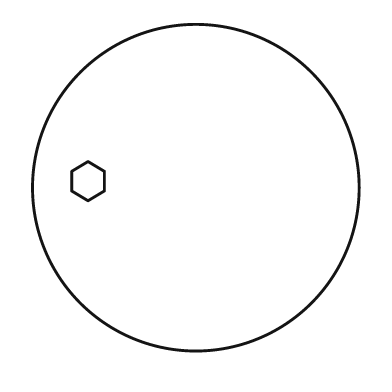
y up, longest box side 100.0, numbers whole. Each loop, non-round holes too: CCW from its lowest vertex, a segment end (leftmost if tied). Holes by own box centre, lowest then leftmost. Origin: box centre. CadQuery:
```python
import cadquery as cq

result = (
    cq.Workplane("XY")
    .moveTo(0.0, 0.0)
    .circle(50.0)
    .moveTo(-33.0, -4.0)
    .lineTo(-28.0, -1.0)
    .lineTo(-28.0, 5.0)
    .lineTo(-33.0, 8.0)
    .lineTo(-38.0, 5.0)
    .lineTo(-38.0, -1.0)
    .close()
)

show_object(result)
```